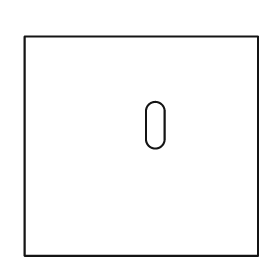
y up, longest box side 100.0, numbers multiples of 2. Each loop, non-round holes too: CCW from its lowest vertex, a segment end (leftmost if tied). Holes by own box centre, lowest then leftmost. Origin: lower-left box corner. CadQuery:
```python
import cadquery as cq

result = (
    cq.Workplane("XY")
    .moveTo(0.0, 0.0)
    .lineTo(100.0, 0.0)
    .lineTo(100.0, 94.0)
    .lineTo(0.0, 94.0)
    .close()
    .moveTo(52.0, 50.0)
    .threePointArc((56.0, 46.0), (60.0, 50.0))
    .lineTo(60.0, 62.0)
    .threePointArc((56.0, 66.0), (52.0, 62.0))
    .close()
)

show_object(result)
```